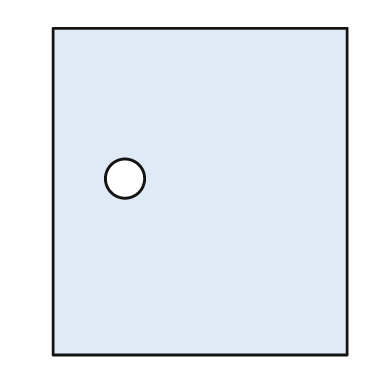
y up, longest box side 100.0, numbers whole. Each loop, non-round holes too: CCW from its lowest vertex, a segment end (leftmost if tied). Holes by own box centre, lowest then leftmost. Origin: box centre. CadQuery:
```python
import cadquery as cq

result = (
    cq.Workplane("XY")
    .moveTo(-45.0, -50.0)
    .lineTo(45.0, -50.0)
    .lineTo(45.0, 50.0)
    .lineTo(-45.0, 50.0)
    .close()
    .moveTo(-23.0, 4.0)
    .circle(6.0)
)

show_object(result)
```